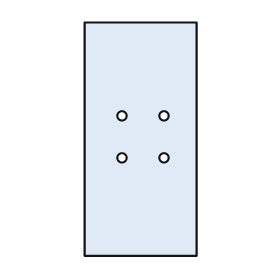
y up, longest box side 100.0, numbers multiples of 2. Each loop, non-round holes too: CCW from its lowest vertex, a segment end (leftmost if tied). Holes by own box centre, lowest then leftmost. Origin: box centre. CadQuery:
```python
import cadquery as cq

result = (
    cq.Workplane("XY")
    .moveTo(-24.0, -50.0)
    .lineTo(24.0, -50.0)
    .lineTo(24.0, 50.0)
    .lineTo(-24.0, 50.0)
    .close()
    .moveTo(-8.0, -8.0)
    .circle(2.0)
    .moveTo(10.0, -8.0)
    .circle(2.0)
    .moveTo(-8.0, 10.0)
    .circle(2.0)
    .moveTo(10.0, 10.0)
    .circle(2.0)
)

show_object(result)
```